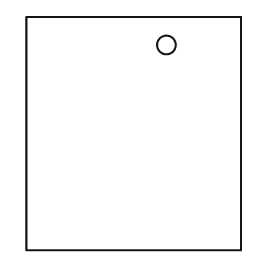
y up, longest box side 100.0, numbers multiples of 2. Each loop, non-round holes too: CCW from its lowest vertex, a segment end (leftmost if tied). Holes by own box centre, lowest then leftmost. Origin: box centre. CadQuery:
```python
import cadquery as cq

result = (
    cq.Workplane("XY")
    .moveTo(-46.0, -50.0)
    .lineTo(46.0, -50.0)
    .lineTo(46.0, 50.0)
    .lineTo(-46.0, 50.0)
    .close()
    .moveTo(14.0, 38.0)
    .circle(4.0)
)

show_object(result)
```